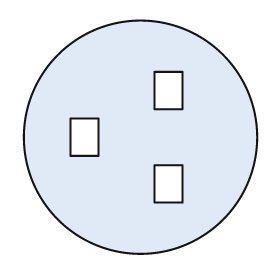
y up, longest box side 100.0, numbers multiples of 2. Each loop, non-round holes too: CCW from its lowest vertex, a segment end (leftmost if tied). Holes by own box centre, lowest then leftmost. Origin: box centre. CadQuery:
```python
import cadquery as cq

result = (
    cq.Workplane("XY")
    .moveTo(0.0, 0.0)
    .circle(50.0)
    .moveTo(6.0, -28.0)
    .lineTo(18.0, -28.0)
    .lineTo(18.0, -12.0)
    .lineTo(6.0, -12.0)
    .close()
    .moveTo(-30.0, -8.0)
    .lineTo(-18.0, -8.0)
    .lineTo(-18.0, 8.0)
    .lineTo(-30.0, 8.0)
    .close()
    .moveTo(6.0, 12.0)
    .lineTo(18.0, 12.0)
    .lineTo(18.0, 28.0)
    .lineTo(6.0, 28.0)
    .close()
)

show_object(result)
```